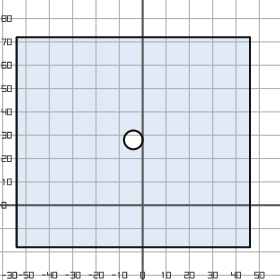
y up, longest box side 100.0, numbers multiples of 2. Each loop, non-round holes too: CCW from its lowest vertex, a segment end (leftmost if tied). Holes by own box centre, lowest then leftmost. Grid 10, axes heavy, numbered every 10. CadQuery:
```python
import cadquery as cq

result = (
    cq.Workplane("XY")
    .moveTo(-54.0, -18.0)
    .lineTo(46.0, -18.0)
    .lineTo(46.0, 72.0)
    .lineTo(-54.0, 72.0)
    .close()
    .moveTo(-4.0, 28.0)
    .circle(4.0)
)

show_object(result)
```